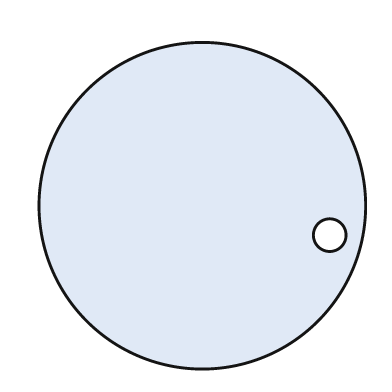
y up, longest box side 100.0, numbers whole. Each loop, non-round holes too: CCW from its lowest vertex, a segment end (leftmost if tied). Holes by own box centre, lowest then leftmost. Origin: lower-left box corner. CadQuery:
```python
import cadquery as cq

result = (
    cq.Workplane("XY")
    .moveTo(50.0, 50.0)
    .circle(50.0)
    .moveTo(89.0, 41.0)
    .circle(5.0)
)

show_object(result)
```